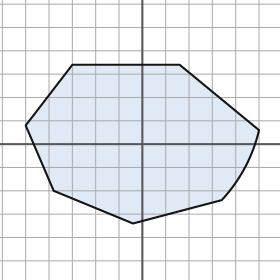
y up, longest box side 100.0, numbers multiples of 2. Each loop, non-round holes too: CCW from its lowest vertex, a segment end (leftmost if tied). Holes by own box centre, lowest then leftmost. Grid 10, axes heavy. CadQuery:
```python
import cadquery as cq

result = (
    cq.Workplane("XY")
    .moveTo(-4.0, -34.0)
    .lineTo(34.0, -24.0)
    .threePointArc((44.0, -10.0), (50.0, 6.0))
    .lineTo(16.0, 34.0)
    .lineTo(-30.0, 34.0)
    .lineTo(-50.0, 8.0)
    .lineTo(-38.0, -20.0)
    .close()
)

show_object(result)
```